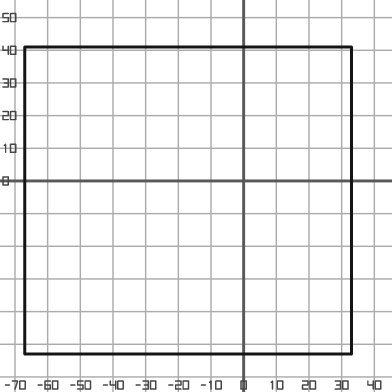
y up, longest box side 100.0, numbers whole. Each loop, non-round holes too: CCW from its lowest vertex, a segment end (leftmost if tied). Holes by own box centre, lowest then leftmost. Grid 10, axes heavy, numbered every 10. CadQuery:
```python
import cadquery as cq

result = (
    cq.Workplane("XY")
    .moveTo(-67.0, -53.0)
    .lineTo(33.0, -53.0)
    .lineTo(33.0, 41.0)
    .lineTo(-67.0, 41.0)
    .close()
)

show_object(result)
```